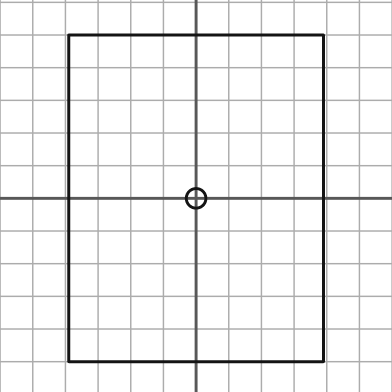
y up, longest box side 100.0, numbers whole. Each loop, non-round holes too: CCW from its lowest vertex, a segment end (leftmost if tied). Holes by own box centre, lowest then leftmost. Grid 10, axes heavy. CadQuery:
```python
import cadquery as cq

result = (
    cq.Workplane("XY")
    .moveTo(-39.0, -50.0)
    .lineTo(39.0, -50.0)
    .lineTo(39.0, 50.0)
    .lineTo(-39.0, 50.0)
    .close()
    .moveTo(0.0, 0.0)
    .circle(3.0)
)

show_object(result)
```